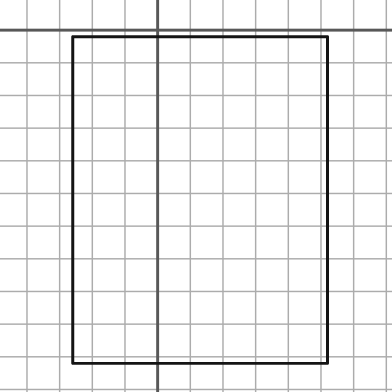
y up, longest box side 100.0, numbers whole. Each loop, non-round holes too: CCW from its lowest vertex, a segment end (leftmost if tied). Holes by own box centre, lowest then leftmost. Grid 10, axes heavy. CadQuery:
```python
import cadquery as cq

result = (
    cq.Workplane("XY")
    .moveTo(-26.0, -102.0)
    .lineTo(52.0, -102.0)
    .lineTo(52.0, -2.0)
    .lineTo(-26.0, -2.0)
    .close()
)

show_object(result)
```